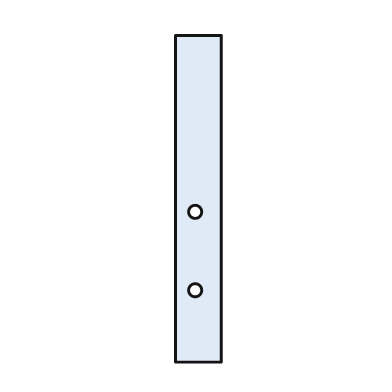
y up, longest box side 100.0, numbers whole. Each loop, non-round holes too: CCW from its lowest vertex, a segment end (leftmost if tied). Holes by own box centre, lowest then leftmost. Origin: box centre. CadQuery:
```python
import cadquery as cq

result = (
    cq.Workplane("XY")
    .moveTo(-7.0, -50.0)
    .lineTo(7.0, -50.0)
    .lineTo(7.0, 50.0)
    .lineTo(-7.0, 50.0)
    .close()
    .moveTo(-1.0, -28.0)
    .circle(2.0)
    .moveTo(-1.0, -4.0)
    .circle(2.0)
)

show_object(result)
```